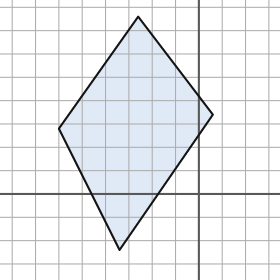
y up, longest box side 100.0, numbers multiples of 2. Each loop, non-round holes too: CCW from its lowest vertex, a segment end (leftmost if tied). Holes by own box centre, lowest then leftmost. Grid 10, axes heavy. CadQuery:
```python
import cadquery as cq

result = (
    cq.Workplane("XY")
    .moveTo(-34.0, -24.0)
    .lineTo(6.0, 34.0)
    .lineTo(-26.0, 76.0)
    .lineTo(-60.0, 28.0)
    .close()
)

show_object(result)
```